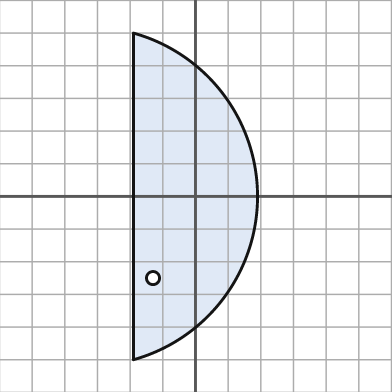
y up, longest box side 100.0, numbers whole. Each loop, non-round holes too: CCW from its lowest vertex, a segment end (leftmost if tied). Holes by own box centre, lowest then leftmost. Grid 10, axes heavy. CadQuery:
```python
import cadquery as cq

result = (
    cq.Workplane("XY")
    .moveTo(-19.0, -50.0)
    .threePointArc((19.0, 0.0), (-19.0, 50.0))
    .close()
    .moveTo(-13.0, -25.0)
    .circle(2.0)
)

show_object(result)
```